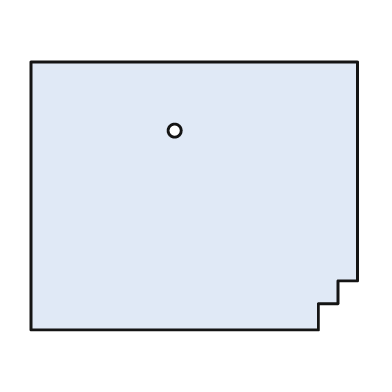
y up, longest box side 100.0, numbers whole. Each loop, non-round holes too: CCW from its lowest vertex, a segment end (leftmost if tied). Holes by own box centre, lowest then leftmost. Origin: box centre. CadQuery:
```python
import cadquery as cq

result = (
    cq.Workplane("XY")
    .moveTo(-50.0, -41.0)
    .lineTo(38.0, -41.0)
    .lineTo(38.0, -33.0)
    .lineTo(44.0, -33.0)
    .lineTo(44.0, -26.0)
    .lineTo(50.0, -26.0)
    .lineTo(50.0, 41.0)
    .lineTo(-50.0, 41.0)
    .close()
    .moveTo(-6.0, 20.0)
    .circle(2.0)
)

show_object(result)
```